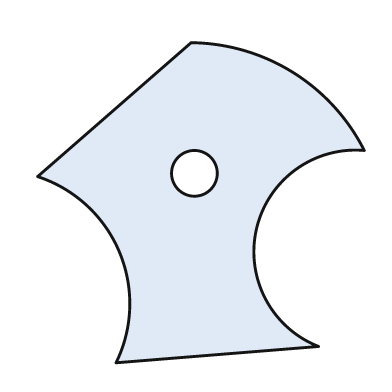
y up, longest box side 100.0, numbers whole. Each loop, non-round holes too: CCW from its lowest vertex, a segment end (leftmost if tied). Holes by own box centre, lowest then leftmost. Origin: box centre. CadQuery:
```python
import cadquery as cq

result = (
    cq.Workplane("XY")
    .moveTo(-26.0, -49.0)
    .lineTo(36.0, -44.0)
    .threePointArc((17.0, -8.0), (50.0, 16.0))
    .threePointArc((28.0, 40.0), (-3.0, 49.0))
    .lineTo(-50.0, 8.0)
    .threePointArc((-25.0, -15.0), (-26.0, -49.0))
    .close()
    .moveTo(-2.0, 9.0)
    .circle(7.0)
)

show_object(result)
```